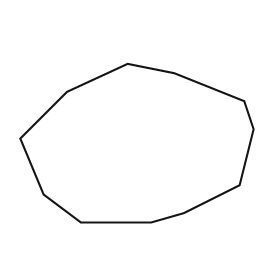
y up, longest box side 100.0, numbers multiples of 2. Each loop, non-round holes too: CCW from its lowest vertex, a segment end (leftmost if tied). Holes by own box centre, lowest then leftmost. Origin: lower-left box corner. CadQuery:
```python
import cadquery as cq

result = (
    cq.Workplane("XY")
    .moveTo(26.0, 0.0)
    .lineTo(56.0, 0.0)
    .lineTo(70.0, 4.0)
    .lineTo(94.0, 16.0)
    .lineTo(100.0, 40.0)
    .lineTo(96.0, 52.0)
    .lineTo(66.0, 64.0)
    .lineTo(46.0, 68.0)
    .lineTo(20.0, 56.0)
    .lineTo(0.0, 36.0)
    .lineTo(10.0, 12.0)
    .close()
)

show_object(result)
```